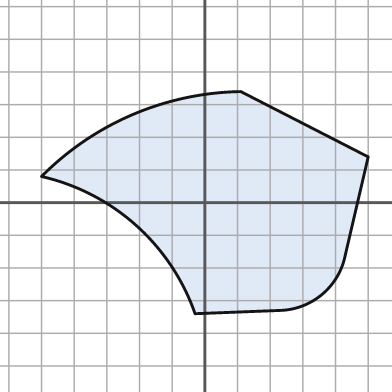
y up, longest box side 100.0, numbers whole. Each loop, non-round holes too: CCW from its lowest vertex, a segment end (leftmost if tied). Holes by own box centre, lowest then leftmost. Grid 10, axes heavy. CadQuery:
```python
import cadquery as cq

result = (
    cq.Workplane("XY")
    .moveTo(-3.0, -34.0)
    .lineTo(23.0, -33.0)
    .threePointArc((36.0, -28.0), (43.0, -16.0))
    .lineTo(50.0, 14.0)
    .lineTo(11.0, 34.0)
    .threePointArc((-22.0, 27.0), (-50.0, 8.0))
    .threePointArc((-21.0, -7.0), (-3.0, -34.0))
    .close()
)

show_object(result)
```